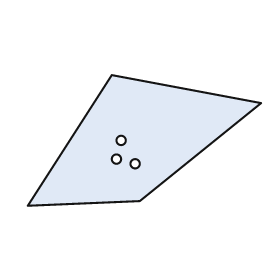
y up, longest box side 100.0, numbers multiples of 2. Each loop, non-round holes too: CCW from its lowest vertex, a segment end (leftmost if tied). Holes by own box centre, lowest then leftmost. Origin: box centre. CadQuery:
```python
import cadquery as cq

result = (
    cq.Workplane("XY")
    .moveTo(-50.0, -28.0)
    .lineTo(-2.0, -26.0)
    .lineTo(50.0, 16.0)
    .lineTo(-14.0, 28.0)
    .close()
    .moveTo(-4.0, -10.0)
    .circle(2.0)
    .moveTo(-12.0, -8.0)
    .circle(2.0)
    .moveTo(-10.0, 0.0)
    .circle(2.0)
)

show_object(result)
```